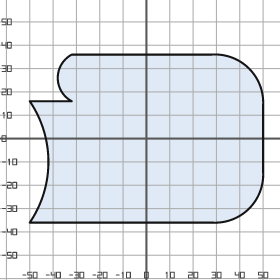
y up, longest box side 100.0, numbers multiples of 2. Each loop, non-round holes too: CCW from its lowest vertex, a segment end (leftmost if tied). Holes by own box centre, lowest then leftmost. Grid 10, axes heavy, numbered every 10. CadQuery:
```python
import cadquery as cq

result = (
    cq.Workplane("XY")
    .moveTo(-50.0, -36.0)
    .lineTo(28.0, -36.0)
    .threePointArc((44.0, -30.0), (50.0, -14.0))
    .lineTo(50.0, 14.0)
    .threePointArc((44.0, 30.0), (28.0, 36.0))
    .lineTo(-32.0, 36.0)
    .threePointArc((-38.0, 26.0), (-32.0, 16.0))
    .lineTo(-50.0, 16.0)
    .threePointArc((-42.0, -10.0), (-50.0, -36.0))
    .close()
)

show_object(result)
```